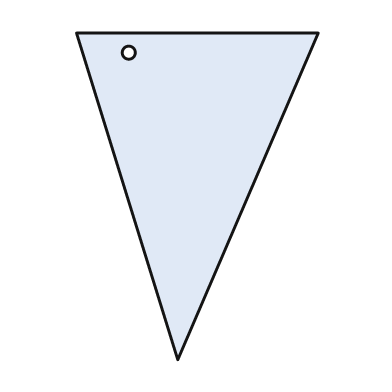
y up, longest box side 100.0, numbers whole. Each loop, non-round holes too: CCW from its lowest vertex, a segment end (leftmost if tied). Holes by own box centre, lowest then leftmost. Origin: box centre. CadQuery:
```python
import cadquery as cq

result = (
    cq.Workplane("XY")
    .moveTo(-6.0, -50.0)
    .lineTo(37.0, 50.0)
    .lineTo(-37.0, 50.0)
    .close()
    .moveTo(-21.0, 44.0)
    .circle(2.0)
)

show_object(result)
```